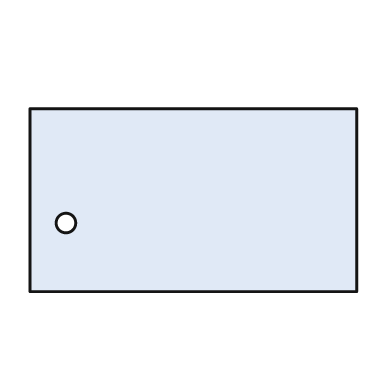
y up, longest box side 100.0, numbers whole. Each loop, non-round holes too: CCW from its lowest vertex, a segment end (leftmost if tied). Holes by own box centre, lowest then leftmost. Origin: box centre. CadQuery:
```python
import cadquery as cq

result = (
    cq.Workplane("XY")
    .moveTo(-50.0, -28.0)
    .lineTo(50.0, -28.0)
    .lineTo(50.0, 28.0)
    .lineTo(-50.0, 28.0)
    .close()
    .moveTo(-39.0, -7.0)
    .circle(3.0)
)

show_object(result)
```